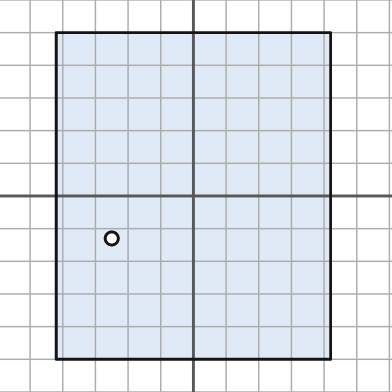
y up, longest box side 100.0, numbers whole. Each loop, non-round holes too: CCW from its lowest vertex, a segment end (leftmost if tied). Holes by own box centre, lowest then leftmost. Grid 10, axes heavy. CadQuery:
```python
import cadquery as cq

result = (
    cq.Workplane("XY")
    .moveTo(-42.0, -50.0)
    .lineTo(42.0, -50.0)
    .lineTo(42.0, 50.0)
    .lineTo(-42.0, 50.0)
    .close()
    .moveTo(-25.0, -13.0)
    .circle(2.0)
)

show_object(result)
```